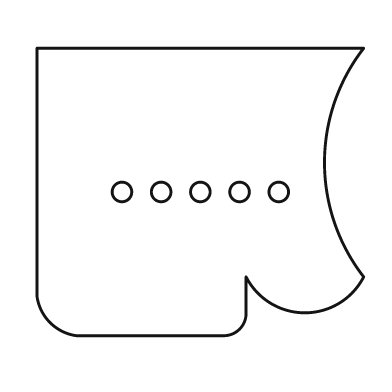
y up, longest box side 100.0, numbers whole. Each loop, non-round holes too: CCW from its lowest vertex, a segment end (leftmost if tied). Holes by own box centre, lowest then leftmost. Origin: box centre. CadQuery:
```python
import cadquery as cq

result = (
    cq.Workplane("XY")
    .moveTo(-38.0, -44.0)
    .lineTo(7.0, -44.0)
    .threePointArc((12.0, -42.0), (14.0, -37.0))
    .lineTo(14.0, -26.0)
    .threePointArc((32.0, -37.0), (50.0, -26.0))
    .threePointArc((38.0, 9.0), (50.0, 44.0))
    .lineTo(-50.0, 44.0)
    .lineTo(-50.0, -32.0)
    .threePointArc((-46.0, -40.0), (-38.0, -44.0))
    .close()
    .moveTo(-24.0, 0.0)
    .circle(3.0)
    .moveTo(-12.0, 0.0)
    .circle(3.0)
    .moveTo(0.0, 0.0)
    .circle(3.0)
    .moveTo(12.0, 0.0)
    .circle(3.0)
    .moveTo(24.0, 0.0)
    .circle(3.0)
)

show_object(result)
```